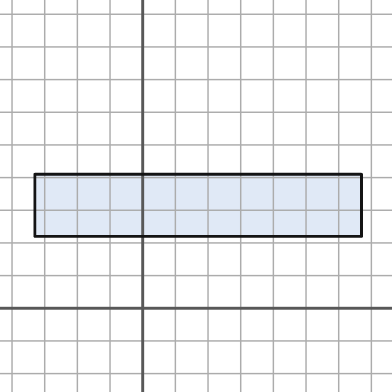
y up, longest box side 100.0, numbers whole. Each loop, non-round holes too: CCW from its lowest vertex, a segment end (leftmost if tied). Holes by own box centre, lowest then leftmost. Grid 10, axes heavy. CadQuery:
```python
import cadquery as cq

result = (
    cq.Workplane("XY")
    .moveTo(-33.0, 22.0)
    .lineTo(67.0, 22.0)
    .lineTo(67.0, 41.0)
    .lineTo(-33.0, 41.0)
    .close()
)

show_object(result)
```